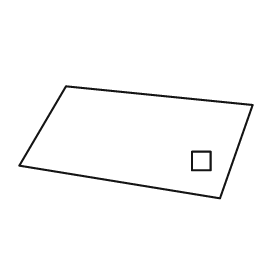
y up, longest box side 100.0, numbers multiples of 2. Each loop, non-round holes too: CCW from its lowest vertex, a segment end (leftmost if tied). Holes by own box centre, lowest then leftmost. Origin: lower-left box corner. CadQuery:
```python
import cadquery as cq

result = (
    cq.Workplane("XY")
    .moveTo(86.0, 0.0)
    .lineTo(100.0, 40.0)
    .lineTo(20.0, 48.0)
    .lineTo(0.0, 14.0)
    .close()
    .moveTo(74.0, 12.0)
    .lineTo(82.0, 12.0)
    .lineTo(82.0, 20.0)
    .lineTo(74.0, 20.0)
    .close()
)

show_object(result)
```